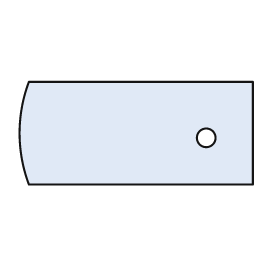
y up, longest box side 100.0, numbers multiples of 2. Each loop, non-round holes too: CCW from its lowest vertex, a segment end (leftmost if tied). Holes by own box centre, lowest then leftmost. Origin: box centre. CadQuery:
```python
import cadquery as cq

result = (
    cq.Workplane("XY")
    .moveTo(-46.0, -22.0)
    .lineTo(50.0, -22.0)
    .lineTo(50.0, 22.0)
    .lineTo(-46.0, 22.0)
    .threePointArc((-50.0, 0.0), (-46.0, -22.0))
    .close()
    .moveTo(30.0, -2.0)
    .circle(4.0)
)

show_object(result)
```